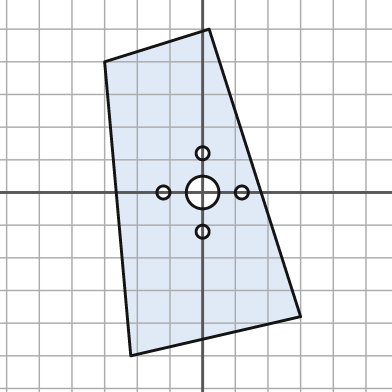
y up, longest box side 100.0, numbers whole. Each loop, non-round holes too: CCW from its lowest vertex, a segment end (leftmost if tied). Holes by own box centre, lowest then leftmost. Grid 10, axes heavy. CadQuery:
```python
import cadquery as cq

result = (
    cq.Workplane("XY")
    .moveTo(-22.0, -50.0)
    .lineTo(30.0, -38.0)
    .lineTo(2.0, 50.0)
    .lineTo(-30.0, 40.0)
    .close()
    .moveTo(0.0, -12.0)
    .circle(2.0)
    .moveTo(-12.0, 0.0)
    .circle(2.0)
    .moveTo(0.0, 0.0)
    .circle(5.0)
    .moveTo(12.0, 0.0)
    .circle(2.0)
    .moveTo(0.0, 12.0)
    .circle(2.0)
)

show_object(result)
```